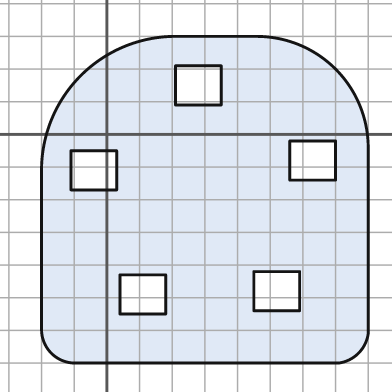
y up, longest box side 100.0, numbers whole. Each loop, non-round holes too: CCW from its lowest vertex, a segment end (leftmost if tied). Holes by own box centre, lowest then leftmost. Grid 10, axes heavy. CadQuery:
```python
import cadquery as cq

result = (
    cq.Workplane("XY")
    .moveTo(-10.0, -70.0)
    .lineTo(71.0, -70.0)
    .threePointArc((77.0, -67.0), (80.0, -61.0))
    .lineTo(80.0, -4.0)
    .threePointArc((70.0, 20.0), (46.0, 30.0))
    .lineTo(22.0, 30.0)
    .threePointArc((-8.0, 18.0), (-20.0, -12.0))
    .lineTo(-20.0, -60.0)
    .threePointArc((-17.0, -67.0), (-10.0, -70.0))
    .close()
    .moveTo(4.0, -55.0)
    .lineTo(18.0, -55.0)
    .lineTo(18.0, -43.0)
    .lineTo(4.0, -43.0)
    .close()
    .moveTo(45.0, -54.0)
    .lineTo(59.0, -54.0)
    .lineTo(59.0, -42.0)
    .lineTo(45.0, -42.0)
    .close()
    .moveTo(-11.0, -17.0)
    .lineTo(3.0, -17.0)
    .lineTo(3.0, -5.0)
    .lineTo(-11.0, -5.0)
    .close()
    .moveTo(56.0, -14.0)
    .lineTo(70.0, -14.0)
    .lineTo(70.0, -2.0)
    .lineTo(56.0, -2.0)
    .close()
    .moveTo(21.0, 9.0)
    .lineTo(35.0, 9.0)
    .lineTo(35.0, 21.0)
    .lineTo(21.0, 21.0)
    .close()
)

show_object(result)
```